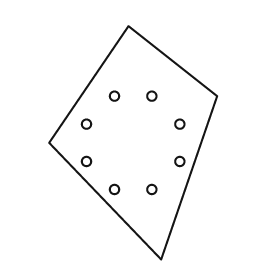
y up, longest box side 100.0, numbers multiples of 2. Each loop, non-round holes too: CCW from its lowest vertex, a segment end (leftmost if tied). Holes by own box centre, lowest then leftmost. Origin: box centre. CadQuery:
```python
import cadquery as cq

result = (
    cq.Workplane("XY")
    .moveTo(12.0, -50.0)
    .lineTo(36.0, 20.0)
    .lineTo(-2.0, 50.0)
    .lineTo(-36.0, 0.0)
    .close()
    .moveTo(-8.0, -20.0)
    .circle(2.0)
    .moveTo(8.0, -20.0)
    .circle(2.0)
    .moveTo(-20.0, -8.0)
    .circle(2.0)
    .moveTo(20.0, -8.0)
    .circle(2.0)
    .moveTo(-20.0, 8.0)
    .circle(2.0)
    .moveTo(20.0, 8.0)
    .circle(2.0)
    .moveTo(-8.0, 20.0)
    .circle(2.0)
    .moveTo(8.0, 20.0)
    .circle(2.0)
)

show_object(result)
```